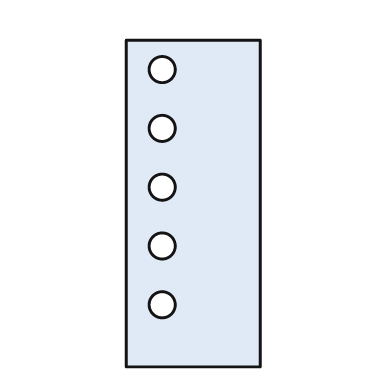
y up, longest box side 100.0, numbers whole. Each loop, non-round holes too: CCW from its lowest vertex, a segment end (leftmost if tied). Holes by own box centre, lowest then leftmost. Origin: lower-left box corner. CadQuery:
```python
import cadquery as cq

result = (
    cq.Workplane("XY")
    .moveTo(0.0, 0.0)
    .lineTo(41.0, 0.0)
    .lineTo(41.0, 100.0)
    .lineTo(0.0, 100.0)
    .close()
    .moveTo(11.0, 19.0)
    .circle(4.0)
    .moveTo(11.0, 37.0)
    .circle(4.0)
    .moveTo(11.0, 55.0)
    .circle(4.0)
    .moveTo(11.0, 73.0)
    .circle(4.0)
    .moveTo(11.0, 91.0)
    .circle(4.0)
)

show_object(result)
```